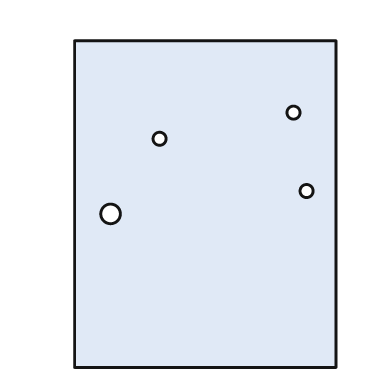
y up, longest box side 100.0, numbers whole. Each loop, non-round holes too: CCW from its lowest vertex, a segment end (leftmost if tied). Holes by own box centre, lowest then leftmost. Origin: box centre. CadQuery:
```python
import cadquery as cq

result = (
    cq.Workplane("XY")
    .moveTo(-40.0, -50.0)
    .lineTo(40.0, -50.0)
    .lineTo(40.0, 50.0)
    .lineTo(-40.0, 50.0)
    .close()
    .moveTo(-29.0, -3.0)
    .circle(3.0)
    .moveTo(31.0, 4.0)
    .circle(2.0)
    .moveTo(-14.0, 20.0)
    .circle(2.0)
    .moveTo(27.0, 28.0)
    .circle(2.0)
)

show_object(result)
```